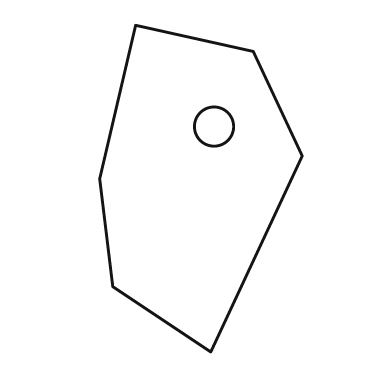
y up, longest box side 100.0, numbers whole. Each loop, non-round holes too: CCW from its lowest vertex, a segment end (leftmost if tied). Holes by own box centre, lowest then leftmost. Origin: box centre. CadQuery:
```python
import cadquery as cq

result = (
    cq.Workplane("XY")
    .moveTo(3.0, -50.0)
    .lineTo(31.0, 10.0)
    .lineTo(16.0, 42.0)
    .lineTo(-20.0, 50.0)
    .lineTo(-31.0, 3.0)
    .lineTo(-27.0, -30.0)
    .close()
    .moveTo(4.0, 19.0)
    .circle(6.0)
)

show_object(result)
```